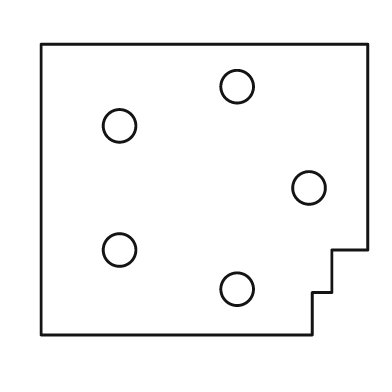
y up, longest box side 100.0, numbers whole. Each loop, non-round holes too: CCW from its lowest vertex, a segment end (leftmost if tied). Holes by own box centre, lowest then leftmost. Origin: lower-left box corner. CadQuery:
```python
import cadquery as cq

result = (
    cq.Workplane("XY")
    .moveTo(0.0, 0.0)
    .lineTo(83.0, 0.0)
    .lineTo(83.0, 13.0)
    .lineTo(89.0, 13.0)
    .lineTo(89.0, 26.0)
    .lineTo(100.0, 26.0)
    .lineTo(100.0, 89.0)
    .lineTo(0.0, 89.0)
    .close()
    .moveTo(60.0, 14.0)
    .circle(5.0)
    .moveTo(24.0, 26.0)
    .circle(5.0)
    .moveTo(82.0, 45.0)
    .circle(5.0)
    .moveTo(24.0, 64.0)
    .circle(5.0)
    .moveTo(60.0, 76.0)
    .circle(5.0)
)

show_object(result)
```